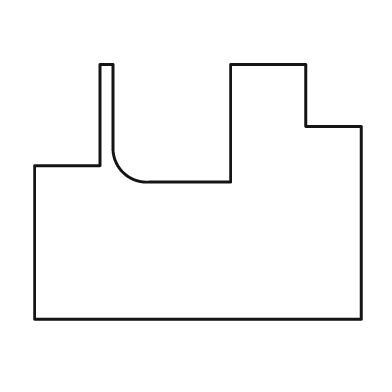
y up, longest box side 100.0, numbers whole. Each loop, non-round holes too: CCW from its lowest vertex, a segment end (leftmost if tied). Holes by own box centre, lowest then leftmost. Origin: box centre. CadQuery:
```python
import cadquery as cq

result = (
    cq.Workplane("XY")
    .moveTo(-50.0, -39.0)
    .lineTo(50.0, -39.0)
    .lineTo(50.0, 20.0)
    .lineTo(33.0, 20.0)
    .lineTo(33.0, 39.0)
    .lineTo(10.0, 39.0)
    .lineTo(10.0, 3.0)
    .lineTo(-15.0, 3.0)
    .threePointArc((-23.0, 6.0), (-26.0, 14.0))
    .lineTo(-26.0, 39.0)
    .lineTo(-30.0, 39.0)
    .lineTo(-30.0, 8.0)
    .lineTo(-50.0, 8.0)
    .close()
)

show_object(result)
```